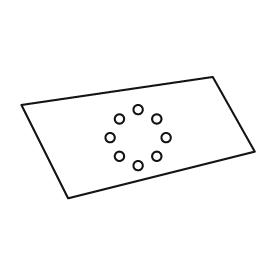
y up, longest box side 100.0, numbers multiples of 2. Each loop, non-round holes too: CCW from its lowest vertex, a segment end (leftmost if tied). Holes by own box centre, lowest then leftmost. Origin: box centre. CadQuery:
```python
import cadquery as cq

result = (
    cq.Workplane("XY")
    .moveTo(-30.0, -26.0)
    .lineTo(50.0, -6.0)
    .lineTo(32.0, 26.0)
    .lineTo(-50.0, 14.0)
    .close()
    .moveTo(0.0, -12.0)
    .circle(2.0)
    .moveTo(-8.0, -8.0)
    .circle(2.0)
    .moveTo(8.0, -8.0)
    .circle(2.0)
    .moveTo(-12.0, 0.0)
    .circle(2.0)
    .moveTo(12.0, 0.0)
    .circle(2.0)
    .moveTo(-8.0, 8.0)
    .circle(2.0)
    .moveTo(8.0, 8.0)
    .circle(2.0)
    .moveTo(0.0, 12.0)
    .circle(2.0)
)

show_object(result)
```